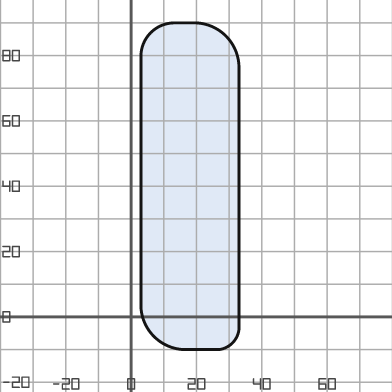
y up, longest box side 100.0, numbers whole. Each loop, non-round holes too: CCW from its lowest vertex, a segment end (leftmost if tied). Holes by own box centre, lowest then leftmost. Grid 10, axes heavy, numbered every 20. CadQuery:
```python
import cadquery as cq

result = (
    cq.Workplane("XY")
    .moveTo(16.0, -10.0)
    .lineTo(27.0, -10.0)
    .threePointArc((31.0, -8.0), (33.0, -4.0))
    .lineTo(33.0, 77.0)
    .threePointArc((29.0, 86.0), (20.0, 90.0))
    .lineTo(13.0, 90.0)
    .threePointArc((6.0, 87.0), (3.0, 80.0))
    .lineTo(3.0, 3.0)
    .threePointArc((7.0, -6.0), (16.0, -10.0))
    .close()
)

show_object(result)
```